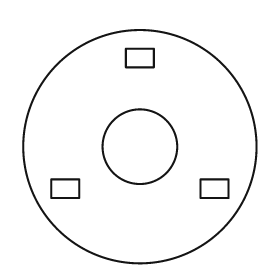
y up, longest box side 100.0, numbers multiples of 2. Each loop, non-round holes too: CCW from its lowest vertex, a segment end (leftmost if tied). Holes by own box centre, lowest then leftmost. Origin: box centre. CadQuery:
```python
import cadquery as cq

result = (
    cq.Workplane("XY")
    .moveTo(0.0, 0.0)
    .circle(50.0)
    .moveTo(-38.0, -22.0)
    .lineTo(-26.0, -22.0)
    .lineTo(-26.0, -14.0)
    .lineTo(-38.0, -14.0)
    .close()
    .moveTo(26.0, -22.0)
    .lineTo(38.0, -22.0)
    .lineTo(38.0, -14.0)
    .lineTo(26.0, -14.0)
    .close()
    .moveTo(0.0, 0.0)
    .circle(16.0)
    .moveTo(-6.0, 34.0)
    .lineTo(6.0, 34.0)
    .lineTo(6.0, 42.0)
    .lineTo(-6.0, 42.0)
    .close()
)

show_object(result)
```